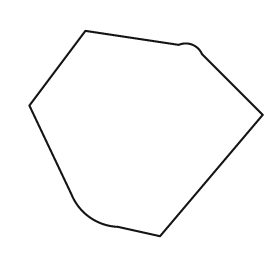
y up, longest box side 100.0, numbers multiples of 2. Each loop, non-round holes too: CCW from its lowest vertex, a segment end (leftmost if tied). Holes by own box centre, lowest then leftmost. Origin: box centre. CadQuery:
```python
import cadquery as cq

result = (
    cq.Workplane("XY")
    .moveTo(6.0, -44.0)
    .lineTo(50.0, 8.0)
    .lineTo(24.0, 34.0)
    .threePointArc((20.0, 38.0), (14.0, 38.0))
    .lineTo(-26.0, 44.0)
    .lineTo(-50.0, 12.0)
    .lineTo(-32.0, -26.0)
    .threePointArc((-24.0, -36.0), (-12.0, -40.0))
    .close()
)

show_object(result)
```